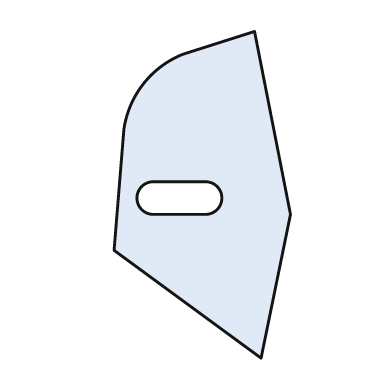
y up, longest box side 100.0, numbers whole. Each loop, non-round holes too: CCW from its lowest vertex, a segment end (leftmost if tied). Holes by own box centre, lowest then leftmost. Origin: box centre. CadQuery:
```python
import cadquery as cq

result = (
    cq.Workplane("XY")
    .moveTo(18.0, -50.0)
    .lineTo(27.0, -6.0)
    .lineTo(16.0, 50.0)
    .lineTo(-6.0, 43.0)
    .threePointArc((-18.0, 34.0), (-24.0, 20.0))
    .lineTo(-27.0, -17.0)
    .close()
    .moveTo(-15.0, -6.0)
    .lineTo(1.0, -6.0)
    .threePointArc((6.0, -1.0), (1.0, 4.0))
    .lineTo(-15.0, 4.0)
    .threePointArc((-20.0, -1.0), (-15.0, -6.0))
    .close()
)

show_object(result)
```